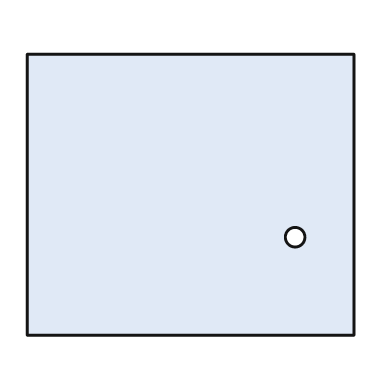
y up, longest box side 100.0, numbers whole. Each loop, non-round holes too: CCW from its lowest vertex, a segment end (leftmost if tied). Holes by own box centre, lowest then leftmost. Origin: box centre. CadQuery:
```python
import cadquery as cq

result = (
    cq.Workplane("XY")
    .moveTo(-50.0, -43.0)
    .lineTo(50.0, -43.0)
    .lineTo(50.0, 43.0)
    .lineTo(-50.0, 43.0)
    .close()
    .moveTo(32.0, -13.0)
    .circle(3.0)
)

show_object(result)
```